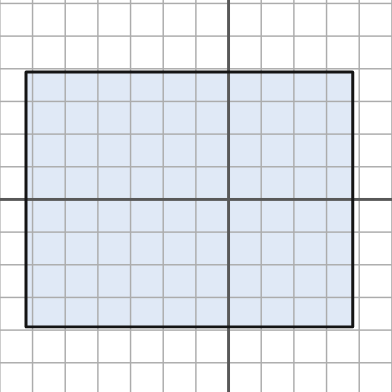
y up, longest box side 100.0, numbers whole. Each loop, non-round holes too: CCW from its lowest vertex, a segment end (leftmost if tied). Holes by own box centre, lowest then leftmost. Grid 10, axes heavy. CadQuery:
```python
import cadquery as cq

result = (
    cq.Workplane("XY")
    .moveTo(-62.0, -39.0)
    .lineTo(38.0, -39.0)
    .lineTo(38.0, 39.0)
    .lineTo(-62.0, 39.0)
    .close()
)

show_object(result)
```